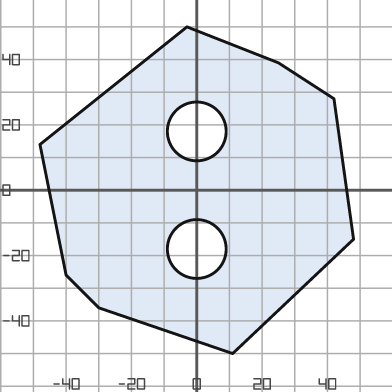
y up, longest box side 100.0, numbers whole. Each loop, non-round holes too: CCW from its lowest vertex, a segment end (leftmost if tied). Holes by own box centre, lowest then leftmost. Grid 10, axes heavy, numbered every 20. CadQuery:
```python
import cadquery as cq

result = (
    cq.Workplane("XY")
    .moveTo(11.0, -50.0)
    .lineTo(48.0, -15.0)
    .lineTo(42.0, 28.0)
    .lineTo(25.0, 39.0)
    .lineTo(-3.0, 50.0)
    .lineTo(-48.0, 14.0)
    .lineTo(-40.0, -26.0)
    .lineTo(-30.0, -36.0)
    .close()
    .moveTo(0.0, -18.0)
    .circle(9.0)
    .moveTo(0.0, 18.0)
    .circle(9.0)
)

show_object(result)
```